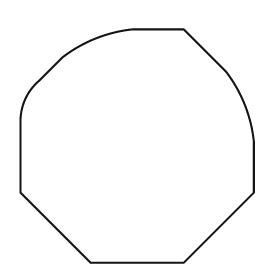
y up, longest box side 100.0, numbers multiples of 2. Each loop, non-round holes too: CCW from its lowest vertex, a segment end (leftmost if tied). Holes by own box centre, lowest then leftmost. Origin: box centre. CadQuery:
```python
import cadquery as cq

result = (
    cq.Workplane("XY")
    .moveTo(-20.0, -50.0)
    .lineTo(20.0, -50.0)
    .lineTo(50.0, -20.0)
    .lineTo(50.0, 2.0)
    .threePointArc((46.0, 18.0), (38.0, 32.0))
    .lineTo(20.0, 50.0)
    .lineTo(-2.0, 50.0)
    .threePointArc((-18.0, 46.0), (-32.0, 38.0))
    .lineTo(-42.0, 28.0)
    .threePointArc((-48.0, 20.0), (-50.0, 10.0))
    .lineTo(-50.0, -20.0)
    .close()
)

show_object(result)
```